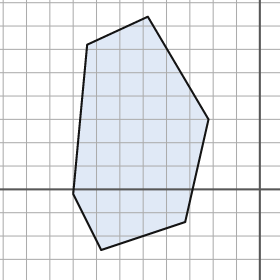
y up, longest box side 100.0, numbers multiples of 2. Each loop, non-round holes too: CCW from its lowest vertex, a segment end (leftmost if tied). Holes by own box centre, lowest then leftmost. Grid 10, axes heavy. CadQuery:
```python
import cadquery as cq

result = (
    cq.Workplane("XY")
    .moveTo(-68.0, -26.0)
    .lineTo(-32.0, -14.0)
    .lineTo(-22.0, 30.0)
    .lineTo(-48.0, 74.0)
    .lineTo(-74.0, 62.0)
    .lineTo(-80.0, -2.0)
    .close()
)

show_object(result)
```